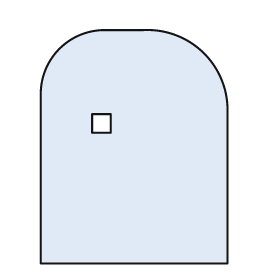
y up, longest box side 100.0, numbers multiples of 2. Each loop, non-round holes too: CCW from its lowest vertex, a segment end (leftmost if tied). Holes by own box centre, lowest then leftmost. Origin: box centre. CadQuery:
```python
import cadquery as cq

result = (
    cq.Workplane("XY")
    .moveTo(-40.0, -50.0)
    .lineTo(40.0, -50.0)
    .lineTo(40.0, 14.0)
    .threePointArc((30.0, 40.0), (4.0, 50.0))
    .lineTo(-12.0, 50.0)
    .threePointArc((-32.0, 42.0), (-40.0, 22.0))
    .close()
    .moveTo(-18.0, 6.0)
    .lineTo(-10.0, 6.0)
    .lineTo(-10.0, 14.0)
    .lineTo(-18.0, 14.0)
    .close()
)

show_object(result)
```